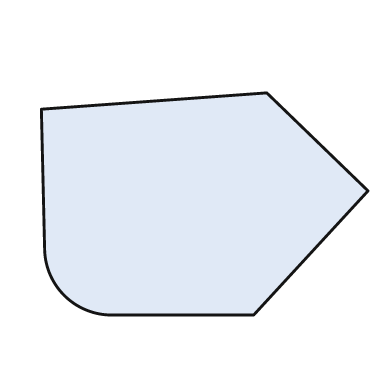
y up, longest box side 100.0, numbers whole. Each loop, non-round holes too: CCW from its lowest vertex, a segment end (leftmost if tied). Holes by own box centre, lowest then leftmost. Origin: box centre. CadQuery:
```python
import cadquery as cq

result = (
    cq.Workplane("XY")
    .moveTo(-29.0, -34.0)
    .lineTo(15.0, -34.0)
    .lineTo(50.0, 4.0)
    .lineTo(19.0, 34.0)
    .lineTo(-50.0, 29.0)
    .lineTo(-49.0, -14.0)
    .threePointArc((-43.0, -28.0), (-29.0, -34.0))
    .close()
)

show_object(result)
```